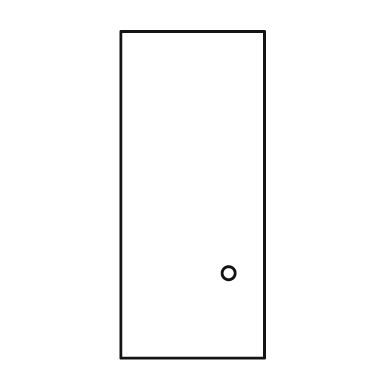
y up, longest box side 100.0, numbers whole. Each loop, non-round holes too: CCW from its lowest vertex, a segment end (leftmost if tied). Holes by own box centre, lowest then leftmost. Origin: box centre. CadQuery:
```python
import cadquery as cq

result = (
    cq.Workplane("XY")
    .moveTo(-22.0, -50.0)
    .lineTo(22.0, -50.0)
    .lineTo(22.0, 50.0)
    .lineTo(-22.0, 50.0)
    .close()
    .moveTo(11.0, -24.0)
    .circle(2.0)
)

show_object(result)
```